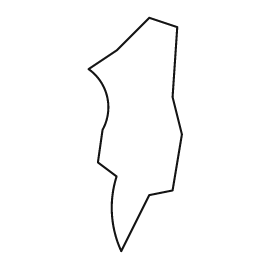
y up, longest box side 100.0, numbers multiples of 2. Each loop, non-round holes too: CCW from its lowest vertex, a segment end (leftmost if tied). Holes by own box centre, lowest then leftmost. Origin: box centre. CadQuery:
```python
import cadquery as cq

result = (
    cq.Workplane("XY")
    .moveTo(-6.0, -50.0)
    .lineTo(6.0, -26.0)
    .lineTo(16.0, -24.0)
    .lineTo(20.0, 0.0)
    .lineTo(16.0, 16.0)
    .lineTo(18.0, 46.0)
    .lineTo(6.0, 50.0)
    .lineTo(-8.0, 36.0)
    .lineTo(-20.0, 28.0)
    .threePointArc((-12.0, 16.0), (-14.0, 2.0))
    .lineTo(-16.0, -12.0)
    .lineTo(-8.0, -18.0)
    .threePointArc((-10.0, -34.0), (-6.0, -50.0))
    .close()
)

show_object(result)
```